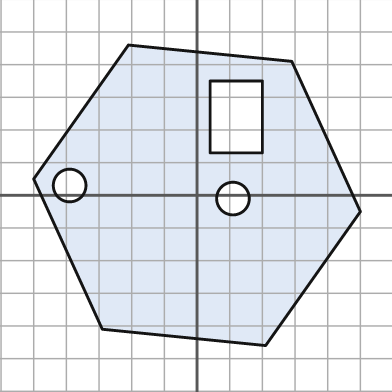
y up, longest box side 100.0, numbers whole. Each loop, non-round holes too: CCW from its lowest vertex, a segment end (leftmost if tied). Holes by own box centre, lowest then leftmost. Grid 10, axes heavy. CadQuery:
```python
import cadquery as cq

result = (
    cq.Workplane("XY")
    .moveTo(21.0, -46.0)
    .lineTo(50.0, -5.0)
    .lineTo(29.0, 41.0)
    .lineTo(-21.0, 46.0)
    .lineTo(-50.0, 5.0)
    .lineTo(-29.0, -41.0)
    .close()
    .moveTo(11.0, -1.0)
    .circle(5.0)
    .moveTo(-39.0, 3.0)
    .circle(5.0)
    .moveTo(4.0, 13.0)
    .lineTo(20.0, 13.0)
    .lineTo(20.0, 35.0)
    .lineTo(4.0, 35.0)
    .close()
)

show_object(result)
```